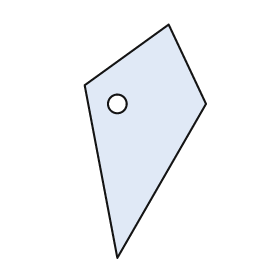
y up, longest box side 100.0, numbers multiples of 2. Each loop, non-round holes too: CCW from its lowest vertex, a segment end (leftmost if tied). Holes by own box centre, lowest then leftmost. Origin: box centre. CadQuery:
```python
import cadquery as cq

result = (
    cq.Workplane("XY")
    .moveTo(-12.0, -50.0)
    .lineTo(26.0, 16.0)
    .lineTo(10.0, 50.0)
    .lineTo(-26.0, 24.0)
    .close()
    .moveTo(-12.0, 16.0)
    .circle(4.0)
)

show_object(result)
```